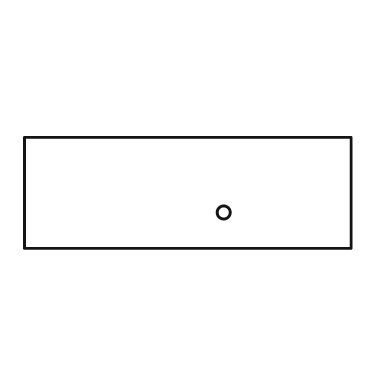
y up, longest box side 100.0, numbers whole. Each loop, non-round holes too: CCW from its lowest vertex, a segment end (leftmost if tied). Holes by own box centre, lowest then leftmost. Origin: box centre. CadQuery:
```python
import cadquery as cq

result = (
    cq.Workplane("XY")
    .moveTo(-50.0, -17.0)
    .lineTo(50.0, -17.0)
    .lineTo(50.0, 17.0)
    .lineTo(-50.0, 17.0)
    .close()
    .moveTo(11.0, -6.0)
    .circle(2.0)
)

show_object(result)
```